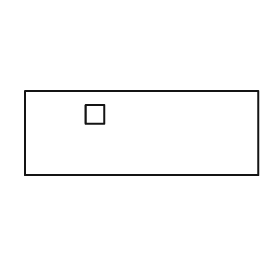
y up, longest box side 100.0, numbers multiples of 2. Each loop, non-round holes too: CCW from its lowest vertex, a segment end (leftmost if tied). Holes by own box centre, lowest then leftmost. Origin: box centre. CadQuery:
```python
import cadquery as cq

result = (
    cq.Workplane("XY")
    .moveTo(-50.0, -18.0)
    .lineTo(50.0, -18.0)
    .lineTo(50.0, 18.0)
    .lineTo(-50.0, 18.0)
    .close()
    .moveTo(-24.0, 4.0)
    .lineTo(-16.0, 4.0)
    .lineTo(-16.0, 12.0)
    .lineTo(-24.0, 12.0)
    .close()
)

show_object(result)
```